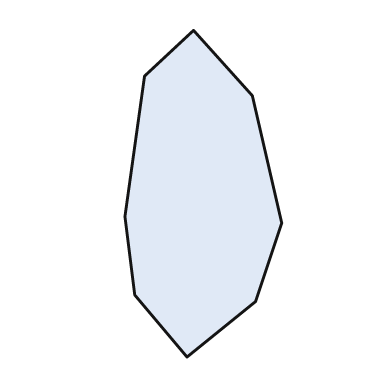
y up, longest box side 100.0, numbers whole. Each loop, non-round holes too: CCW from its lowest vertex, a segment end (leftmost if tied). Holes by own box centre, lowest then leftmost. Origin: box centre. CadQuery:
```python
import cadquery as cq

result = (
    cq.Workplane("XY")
    .moveTo(-5.0, -50.0)
    .lineTo(16.0, -33.0)
    .lineTo(24.0, -9.0)
    .lineTo(15.0, 30.0)
    .lineTo(-3.0, 50.0)
    .lineTo(-18.0, 36.0)
    .lineTo(-24.0, -7.0)
    .lineTo(-21.0, -31.0)
    .close()
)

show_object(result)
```